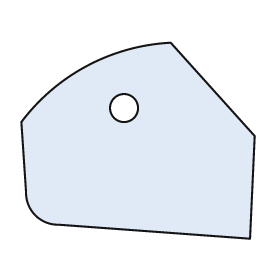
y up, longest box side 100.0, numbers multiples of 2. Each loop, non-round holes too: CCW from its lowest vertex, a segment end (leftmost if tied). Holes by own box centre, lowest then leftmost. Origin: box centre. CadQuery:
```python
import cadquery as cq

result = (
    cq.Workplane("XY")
    .moveTo(48.0, -42.0)
    .lineTo(50.0, 2.0)
    .lineTo(14.0, 42.0)
    .threePointArc((-22.0, 32.0), (-50.0, 8.0))
    .lineTo(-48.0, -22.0)
    .threePointArc((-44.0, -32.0), (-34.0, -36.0))
    .close()
    .moveTo(-6.0, 14.0)
    .circle(6.0)
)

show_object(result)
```